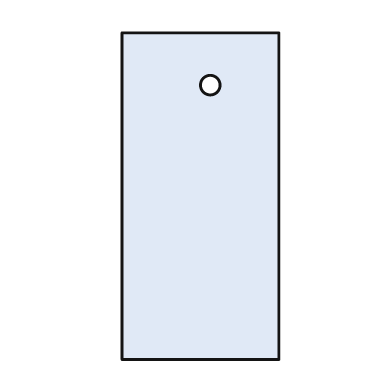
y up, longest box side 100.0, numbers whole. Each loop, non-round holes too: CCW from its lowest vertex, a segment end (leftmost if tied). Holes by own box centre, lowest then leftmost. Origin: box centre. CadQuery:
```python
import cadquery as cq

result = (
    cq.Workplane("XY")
    .moveTo(-24.0, -50.0)
    .lineTo(24.0, -50.0)
    .lineTo(24.0, 50.0)
    .lineTo(-24.0, 50.0)
    .close()
    .moveTo(3.0, 34.0)
    .circle(3.0)
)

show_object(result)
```